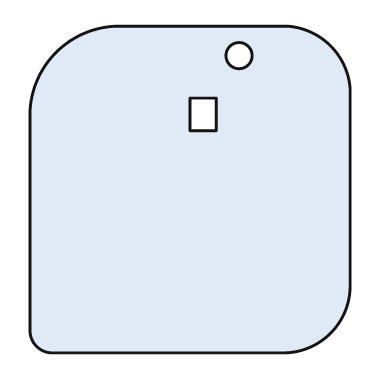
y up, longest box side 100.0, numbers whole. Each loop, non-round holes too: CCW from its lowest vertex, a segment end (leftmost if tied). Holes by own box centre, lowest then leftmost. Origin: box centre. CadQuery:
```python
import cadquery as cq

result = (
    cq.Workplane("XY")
    .moveTo(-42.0, -50.0)
    .lineTo(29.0, -50.0)
    .threePointArc((43.0, -44.0), (49.0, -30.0))
    .lineTo(49.0, 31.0)
    .threePointArc((43.0, 44.0), (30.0, 50.0))
    .lineTo(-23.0, 50.0)
    .threePointArc((-41.0, 42.0), (-49.0, 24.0))
    .lineTo(-49.0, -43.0)
    .threePointArc((-47.0, -48.0), (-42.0, -50.0))
    .close()
    .moveTo(0.0, 18.0)
    .lineTo(8.0, 18.0)
    .lineTo(8.0, 28.0)
    .lineTo(0.0, 28.0)
    .close()
    .moveTo(15.0, 41.0)
    .circle(4.0)
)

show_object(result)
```